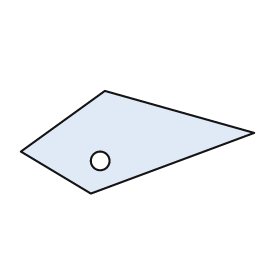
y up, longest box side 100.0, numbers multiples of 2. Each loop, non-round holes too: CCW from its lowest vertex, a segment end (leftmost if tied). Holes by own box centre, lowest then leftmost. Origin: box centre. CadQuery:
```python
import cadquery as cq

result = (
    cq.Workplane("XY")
    .moveTo(-20.0, -22.0)
    .lineTo(50.0, 4.0)
    .lineTo(-14.0, 22.0)
    .lineTo(-50.0, -4.0)
    .close()
    .moveTo(-16.0, -8.0)
    .circle(4.0)
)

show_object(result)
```